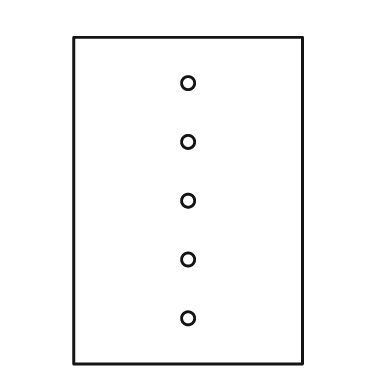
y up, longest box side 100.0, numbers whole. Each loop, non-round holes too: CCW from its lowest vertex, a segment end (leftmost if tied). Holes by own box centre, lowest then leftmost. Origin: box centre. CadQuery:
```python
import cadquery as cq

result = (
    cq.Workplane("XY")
    .moveTo(-35.0, -50.0)
    .lineTo(35.0, -50.0)
    .lineTo(35.0, 50.0)
    .lineTo(-35.0, 50.0)
    .close()
    .moveTo(0.0, -36.0)
    .circle(2.0)
    .moveTo(0.0, -18.0)
    .circle(2.0)
    .moveTo(0.0, 0.0)
    .circle(2.0)
    .moveTo(0.0, 18.0)
    .circle(2.0)
    .moveTo(0.0, 36.0)
    .circle(2.0)
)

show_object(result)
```